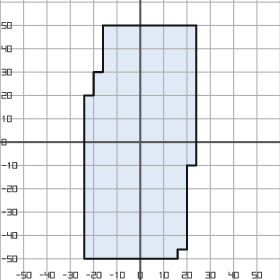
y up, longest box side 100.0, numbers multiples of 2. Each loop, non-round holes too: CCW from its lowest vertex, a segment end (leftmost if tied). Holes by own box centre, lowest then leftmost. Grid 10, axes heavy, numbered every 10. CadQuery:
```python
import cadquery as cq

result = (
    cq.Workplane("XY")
    .moveTo(-24.0, -50.0)
    .lineTo(16.0, -50.0)
    .lineTo(16.0, -46.0)
    .lineTo(20.0, -46.0)
    .lineTo(20.0, -10.0)
    .lineTo(24.0, -10.0)
    .lineTo(24.0, 50.0)
    .lineTo(-16.0, 50.0)
    .lineTo(-16.0, 30.0)
    .lineTo(-20.0, 30.0)
    .lineTo(-20.0, 20.0)
    .lineTo(-24.0, 20.0)
    .close()
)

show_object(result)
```